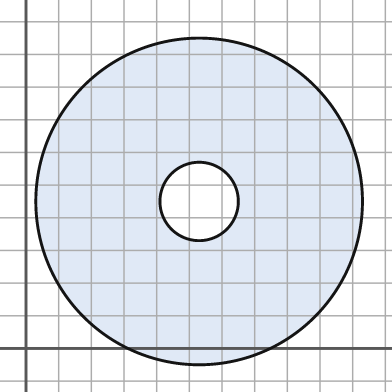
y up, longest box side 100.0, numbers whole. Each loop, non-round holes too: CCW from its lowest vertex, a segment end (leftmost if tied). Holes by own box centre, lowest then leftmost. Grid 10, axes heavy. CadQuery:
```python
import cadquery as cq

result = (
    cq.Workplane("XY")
    .moveTo(53.0, 45.0)
    .circle(50.0)
    .moveTo(53.0, 45.0)
    .circle(12.0)
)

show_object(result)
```